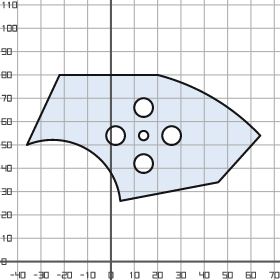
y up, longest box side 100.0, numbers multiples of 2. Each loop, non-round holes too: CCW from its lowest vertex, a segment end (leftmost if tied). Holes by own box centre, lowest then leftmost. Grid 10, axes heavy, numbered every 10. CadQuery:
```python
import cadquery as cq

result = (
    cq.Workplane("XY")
    .moveTo(4.0, 26.0)
    .lineTo(46.0, 34.0)
    .lineTo(64.0, 54.0)
    .threePointArc((44.0, 70.0), (20.0, 80.0))
    .lineTo(-22.0, 80.0)
    .lineTo(-36.0, 50.0)
    .threePointArc((-10.0, 48.0), (4.0, 26.0))
    .close()
    .moveTo(14.0, 42.0)
    .circle(4.0)
    .moveTo(2.0, 54.0)
    .circle(4.0)
    .moveTo(14.0, 54.0)
    .circle(2.0)
    .moveTo(26.0, 54.0)
    .circle(4.0)
    .moveTo(14.0, 66.0)
    .circle(4.0)
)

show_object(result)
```